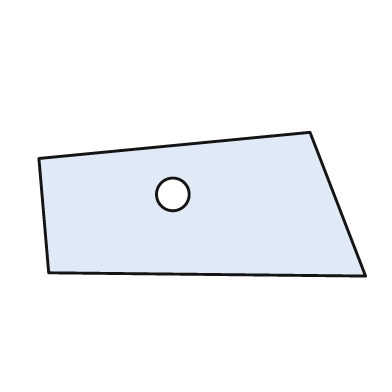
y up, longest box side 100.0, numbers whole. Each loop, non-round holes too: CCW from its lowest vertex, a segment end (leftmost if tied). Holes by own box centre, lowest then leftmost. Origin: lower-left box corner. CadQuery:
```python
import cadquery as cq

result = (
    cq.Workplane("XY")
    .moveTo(100.0, 0.0)
    .lineTo(83.0, 44.0)
    .lineTo(0.0, 36.0)
    .lineTo(3.0, 1.0)
    .close()
    .moveTo(41.0, 25.0)
    .circle(5.0)
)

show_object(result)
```